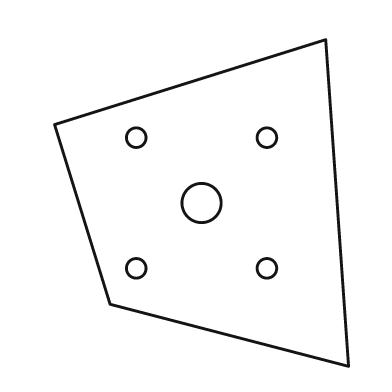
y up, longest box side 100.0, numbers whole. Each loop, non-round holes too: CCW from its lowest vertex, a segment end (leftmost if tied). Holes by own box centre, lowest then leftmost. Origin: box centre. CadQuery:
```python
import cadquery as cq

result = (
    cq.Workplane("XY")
    .moveTo(45.0, -50.0)
    .lineTo(38.0, 50.0)
    .lineTo(-45.0, 24.0)
    .lineTo(-28.0, -31.0)
    .close()
    .moveTo(-20.0, -20.0)
    .circle(3.0)
    .moveTo(20.0, -20.0)
    .circle(3.0)
    .moveTo(0.0, 0.0)
    .circle(6.0)
    .moveTo(-20.0, 20.0)
    .circle(3.0)
    .moveTo(20.0, 20.0)
    .circle(3.0)
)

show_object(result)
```